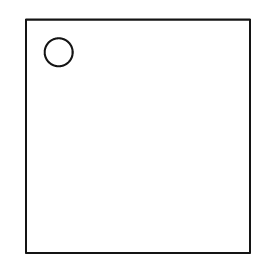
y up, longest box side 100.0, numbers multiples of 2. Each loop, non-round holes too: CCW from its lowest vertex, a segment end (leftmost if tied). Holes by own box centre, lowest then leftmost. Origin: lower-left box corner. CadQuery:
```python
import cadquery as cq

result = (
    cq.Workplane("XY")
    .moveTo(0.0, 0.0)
    .lineTo(96.0, 0.0)
    .lineTo(96.0, 100.0)
    .lineTo(0.0, 100.0)
    .close()
    .moveTo(14.0, 86.0)
    .circle(6.0)
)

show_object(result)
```